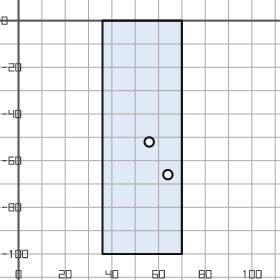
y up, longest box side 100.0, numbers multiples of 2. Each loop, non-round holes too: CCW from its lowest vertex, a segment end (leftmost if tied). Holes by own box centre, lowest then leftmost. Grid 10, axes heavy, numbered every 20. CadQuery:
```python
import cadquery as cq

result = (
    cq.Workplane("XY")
    .moveTo(36.0, -100.0)
    .lineTo(70.0, -100.0)
    .lineTo(70.0, 0.0)
    .lineTo(36.0, 0.0)
    .close()
    .moveTo(64.0, -66.0)
    .circle(2.0)
    .moveTo(56.0, -52.0)
    .circle(2.0)
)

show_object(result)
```